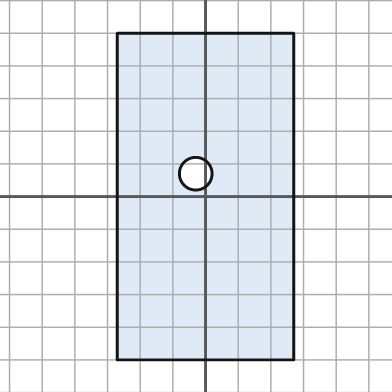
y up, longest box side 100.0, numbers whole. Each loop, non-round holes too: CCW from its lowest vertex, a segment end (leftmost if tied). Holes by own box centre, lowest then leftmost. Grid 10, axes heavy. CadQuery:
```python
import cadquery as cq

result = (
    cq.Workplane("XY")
    .moveTo(-27.0, -50.0)
    .lineTo(27.0, -50.0)
    .lineTo(27.0, 50.0)
    .lineTo(-27.0, 50.0)
    .close()
    .moveTo(-3.0, 7.0)
    .circle(5.0)
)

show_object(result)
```